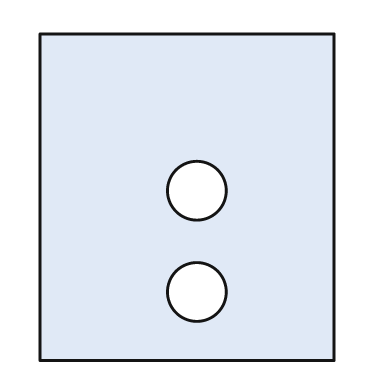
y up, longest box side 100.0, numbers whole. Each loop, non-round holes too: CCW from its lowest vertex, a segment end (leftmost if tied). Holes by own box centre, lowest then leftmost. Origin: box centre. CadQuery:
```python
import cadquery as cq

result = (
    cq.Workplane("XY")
    .moveTo(-45.0, -50.0)
    .lineTo(45.0, -50.0)
    .lineTo(45.0, 50.0)
    .lineTo(-45.0, 50.0)
    .close()
    .moveTo(3.0, -29.0)
    .circle(9.0)
    .moveTo(3.0, 2.0)
    .circle(9.0)
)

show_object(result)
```